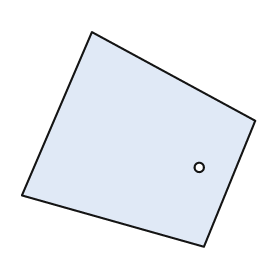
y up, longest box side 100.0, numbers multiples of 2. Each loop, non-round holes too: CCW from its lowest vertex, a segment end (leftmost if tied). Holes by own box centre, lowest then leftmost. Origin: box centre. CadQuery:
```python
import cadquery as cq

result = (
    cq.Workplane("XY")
    .moveTo(28.0, -46.0)
    .lineTo(50.0, 8.0)
    .lineTo(-20.0, 46.0)
    .lineTo(-50.0, -24.0)
    .close()
    .moveTo(26.0, -12.0)
    .circle(2.0)
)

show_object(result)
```